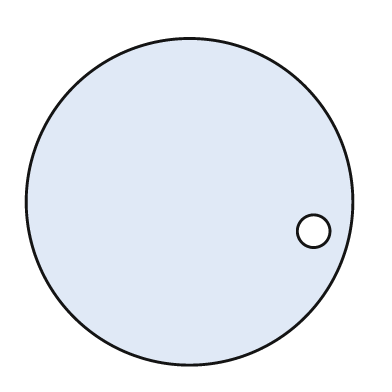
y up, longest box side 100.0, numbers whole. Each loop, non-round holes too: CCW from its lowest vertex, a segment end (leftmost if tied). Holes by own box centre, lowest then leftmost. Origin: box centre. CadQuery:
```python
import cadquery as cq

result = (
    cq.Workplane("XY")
    .moveTo(0.0, 0.0)
    .circle(50.0)
    .moveTo(38.0, -9.0)
    .circle(5.0)
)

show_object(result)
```